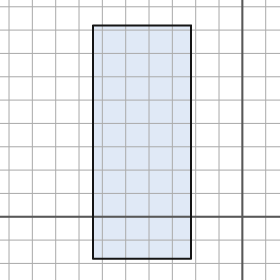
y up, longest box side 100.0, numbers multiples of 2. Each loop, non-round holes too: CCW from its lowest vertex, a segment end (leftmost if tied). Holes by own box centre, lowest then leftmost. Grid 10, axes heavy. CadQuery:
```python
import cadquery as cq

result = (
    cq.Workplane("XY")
    .moveTo(-64.0, -18.0)
    .lineTo(-22.0, -18.0)
    .lineTo(-22.0, 82.0)
    .lineTo(-64.0, 82.0)
    .close()
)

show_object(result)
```